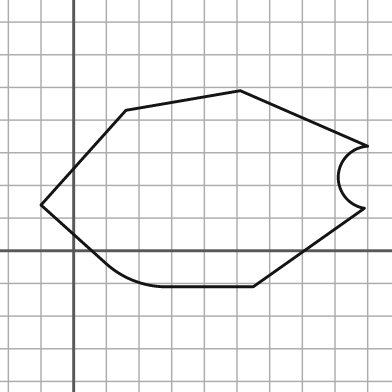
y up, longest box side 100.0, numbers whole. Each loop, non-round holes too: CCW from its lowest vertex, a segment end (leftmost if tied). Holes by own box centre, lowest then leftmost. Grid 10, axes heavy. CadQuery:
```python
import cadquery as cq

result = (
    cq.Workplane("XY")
    .moveTo(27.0, -11.0)
    .lineTo(55.0, -11.0)
    .lineTo(89.0, 13.0)
    .threePointArc((81.0, 23.0), (90.0, 32.0))
    .lineTo(51.0, 49.0)
    .lineTo(16.0, 43.0)
    .lineTo(-10.0, 14.0)
    .lineTo(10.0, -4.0)
    .threePointArc((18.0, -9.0), (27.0, -11.0))
    .close()
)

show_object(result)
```